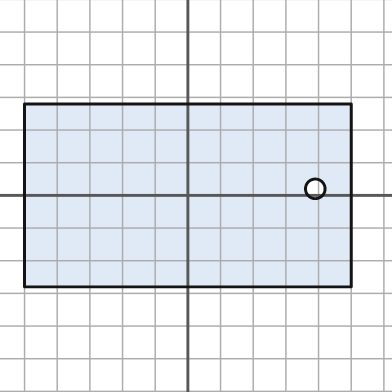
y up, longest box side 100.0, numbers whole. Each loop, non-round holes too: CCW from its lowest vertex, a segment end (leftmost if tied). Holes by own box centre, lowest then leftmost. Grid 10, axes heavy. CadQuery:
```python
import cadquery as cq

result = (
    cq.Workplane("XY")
    .moveTo(-50.0, -28.0)
    .lineTo(50.0, -28.0)
    .lineTo(50.0, 28.0)
    .lineTo(-50.0, 28.0)
    .close()
    .moveTo(39.0, 2.0)
    .circle(3.0)
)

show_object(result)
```